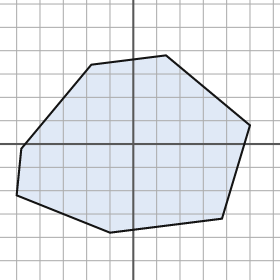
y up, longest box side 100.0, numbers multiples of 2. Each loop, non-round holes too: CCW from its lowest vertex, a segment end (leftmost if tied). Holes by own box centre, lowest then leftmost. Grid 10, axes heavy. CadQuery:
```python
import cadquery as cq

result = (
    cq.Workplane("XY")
    .moveTo(-10.0, -38.0)
    .lineTo(38.0, -32.0)
    .lineTo(50.0, 8.0)
    .lineTo(14.0, 38.0)
    .lineTo(-18.0, 34.0)
    .lineTo(-48.0, -2.0)
    .lineTo(-50.0, -22.0)
    .close()
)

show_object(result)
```